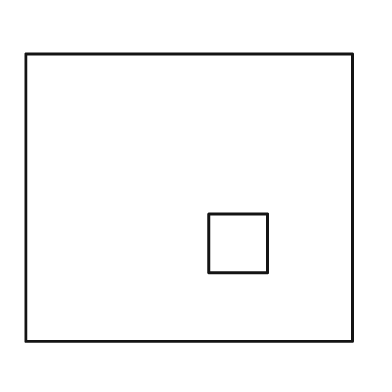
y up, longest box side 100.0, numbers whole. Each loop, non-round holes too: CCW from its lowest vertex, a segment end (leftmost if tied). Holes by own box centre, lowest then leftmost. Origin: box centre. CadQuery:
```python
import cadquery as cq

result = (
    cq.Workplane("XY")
    .moveTo(-50.0, -44.0)
    .lineTo(50.0, -44.0)
    .lineTo(50.0, 44.0)
    .lineTo(-50.0, 44.0)
    .close()
    .moveTo(6.0, -23.0)
    .lineTo(24.0, -23.0)
    .lineTo(24.0, -5.0)
    .lineTo(6.0, -5.0)
    .close()
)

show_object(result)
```